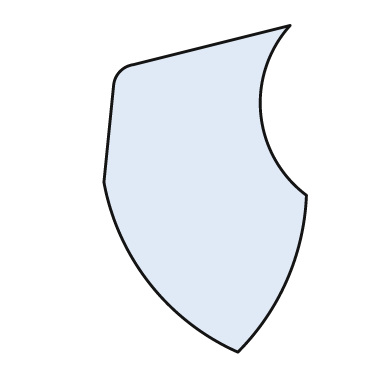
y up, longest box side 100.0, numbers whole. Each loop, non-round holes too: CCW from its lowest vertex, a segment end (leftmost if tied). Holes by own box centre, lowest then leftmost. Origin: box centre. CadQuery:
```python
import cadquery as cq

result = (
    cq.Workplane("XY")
    .moveTo(10.0, -50.0)
    .threePointArc((25.0, -28.0), (31.0, -2.0))
    .threePointArc((17.0, 23.0), (26.0, 50.0))
    .lineTo(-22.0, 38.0)
    .threePointArc((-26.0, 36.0), (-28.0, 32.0))
    .lineTo(-31.0, 2.0)
    .threePointArc((-17.0, -29.0), (10.0, -50.0))
    .close()
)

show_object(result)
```